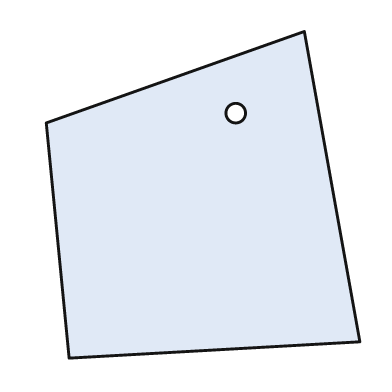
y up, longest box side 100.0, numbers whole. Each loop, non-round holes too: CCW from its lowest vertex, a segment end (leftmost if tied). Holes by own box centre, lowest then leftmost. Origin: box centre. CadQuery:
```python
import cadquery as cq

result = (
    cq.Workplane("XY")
    .moveTo(-41.0, -50.0)
    .lineTo(48.0, -45.0)
    .lineTo(31.0, 50.0)
    .lineTo(-48.0, 22.0)
    .close()
    .moveTo(10.0, 25.0)
    .circle(3.0)
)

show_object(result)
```